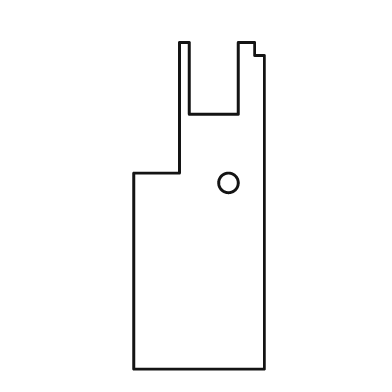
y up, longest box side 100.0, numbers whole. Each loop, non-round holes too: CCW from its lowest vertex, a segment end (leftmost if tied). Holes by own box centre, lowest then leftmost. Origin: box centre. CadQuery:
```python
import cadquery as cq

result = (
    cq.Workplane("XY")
    .moveTo(-20.0, -50.0)
    .lineTo(20.0, -50.0)
    .lineTo(20.0, 46.0)
    .lineTo(17.0, 46.0)
    .lineTo(17.0, 50.0)
    .lineTo(12.0, 50.0)
    .lineTo(12.0, 28.0)
    .lineTo(-3.0, 28.0)
    .lineTo(-3.0, 50.0)
    .lineTo(-6.0, 50.0)
    .lineTo(-6.0, 10.0)
    .lineTo(-20.0, 10.0)
    .close()
    .moveTo(9.0, 7.0)
    .circle(3.0)
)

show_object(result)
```